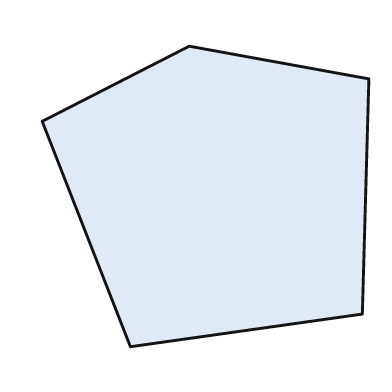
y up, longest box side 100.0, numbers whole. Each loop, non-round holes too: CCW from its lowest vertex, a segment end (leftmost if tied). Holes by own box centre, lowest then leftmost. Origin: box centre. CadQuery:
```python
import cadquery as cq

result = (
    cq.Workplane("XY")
    .moveTo(-23.0, -46.0)
    .lineTo(48.0, -36.0)
    .lineTo(50.0, 36.0)
    .lineTo(-5.0, 46.0)
    .lineTo(-50.0, 23.0)
    .close()
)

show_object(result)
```